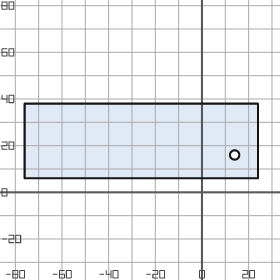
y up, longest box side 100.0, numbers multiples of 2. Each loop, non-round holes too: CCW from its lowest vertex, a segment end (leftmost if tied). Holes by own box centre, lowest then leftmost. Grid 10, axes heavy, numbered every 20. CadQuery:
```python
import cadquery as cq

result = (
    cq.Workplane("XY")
    .moveTo(-76.0, 6.0)
    .lineTo(24.0, 6.0)
    .lineTo(24.0, 38.0)
    .lineTo(-76.0, 38.0)
    .close()
    .moveTo(14.0, 16.0)
    .circle(2.0)
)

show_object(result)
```